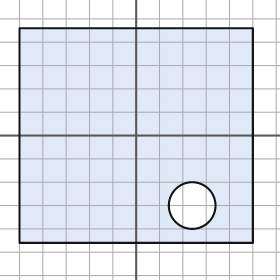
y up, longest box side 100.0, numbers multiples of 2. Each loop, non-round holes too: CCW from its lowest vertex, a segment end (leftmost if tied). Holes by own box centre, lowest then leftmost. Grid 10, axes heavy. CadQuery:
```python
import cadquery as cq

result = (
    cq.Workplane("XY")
    .moveTo(-50.0, -46.0)
    .lineTo(50.0, -46.0)
    .lineTo(50.0, 46.0)
    .lineTo(-50.0, 46.0)
    .close()
    .moveTo(24.0, -30.0)
    .circle(10.0)
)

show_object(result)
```